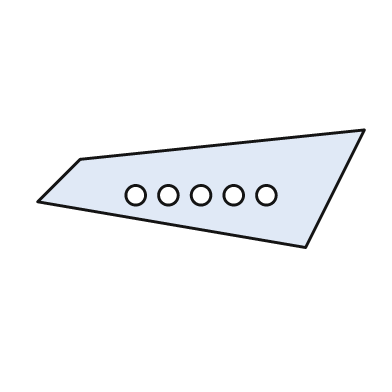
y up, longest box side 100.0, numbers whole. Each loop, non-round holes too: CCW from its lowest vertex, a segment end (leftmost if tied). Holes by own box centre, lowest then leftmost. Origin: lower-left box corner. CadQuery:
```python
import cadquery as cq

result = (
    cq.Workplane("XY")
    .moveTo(82.0, 0.0)
    .lineTo(100.0, 36.0)
    .lineTo(13.0, 27.0)
    .lineTo(0.0, 14.0)
    .close()
    .moveTo(30.0, 16.0)
    .circle(3.0)
    .moveTo(40.0, 16.0)
    .circle(3.0)
    .moveTo(50.0, 16.0)
    .circle(3.0)
    .moveTo(60.0, 16.0)
    .circle(3.0)
    .moveTo(70.0, 16.0)
    .circle(3.0)
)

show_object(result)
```